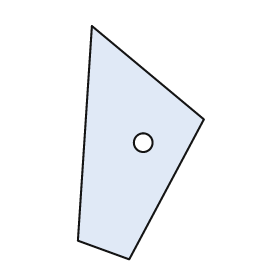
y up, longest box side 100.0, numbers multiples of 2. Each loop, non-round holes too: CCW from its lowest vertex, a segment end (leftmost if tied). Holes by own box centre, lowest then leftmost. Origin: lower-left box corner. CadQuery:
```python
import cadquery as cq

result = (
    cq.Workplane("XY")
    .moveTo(22.0, 0.0)
    .lineTo(54.0, 60.0)
    .lineTo(6.0, 100.0)
    .lineTo(0.0, 8.0)
    .close()
    .moveTo(28.0, 50.0)
    .circle(4.0)
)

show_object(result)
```